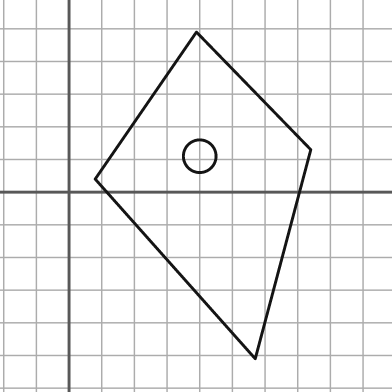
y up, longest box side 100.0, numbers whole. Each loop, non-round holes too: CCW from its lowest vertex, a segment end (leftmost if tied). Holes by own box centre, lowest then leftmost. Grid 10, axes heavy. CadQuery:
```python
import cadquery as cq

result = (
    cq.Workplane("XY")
    .moveTo(57.0, -51.0)
    .lineTo(74.0, 13.0)
    .lineTo(39.0, 49.0)
    .lineTo(8.0, 4.0)
    .close()
    .moveTo(40.0, 11.0)
    .circle(5.0)
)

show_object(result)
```